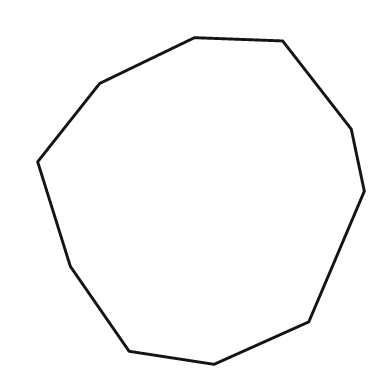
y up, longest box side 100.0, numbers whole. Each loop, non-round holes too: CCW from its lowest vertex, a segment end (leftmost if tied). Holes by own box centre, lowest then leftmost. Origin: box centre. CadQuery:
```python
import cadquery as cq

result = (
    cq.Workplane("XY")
    .moveTo(4.0, -50.0)
    .lineTo(33.0, -37.0)
    .lineTo(50.0, 3.0)
    .lineTo(46.0, 22.0)
    .lineTo(25.0, 49.0)
    .lineTo(-2.0, 50.0)
    .lineTo(-31.0, 36.0)
    .lineTo(-50.0, 12.0)
    .lineTo(-40.0, -20.0)
    .lineTo(-22.0, -46.0)
    .close()
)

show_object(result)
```